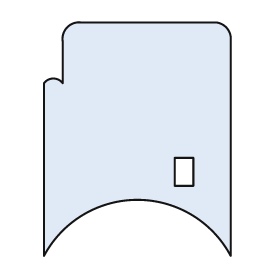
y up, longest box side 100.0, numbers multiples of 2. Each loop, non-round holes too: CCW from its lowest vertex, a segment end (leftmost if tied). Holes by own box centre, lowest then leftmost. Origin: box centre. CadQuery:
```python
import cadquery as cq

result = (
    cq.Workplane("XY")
    .moveTo(-40.0, -50.0)
    .threePointArc((0.0, -26.0), (40.0, -50.0))
    .lineTo(40.0, 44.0)
    .threePointArc((38.0, 48.0), (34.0, 50.0))
    .lineTo(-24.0, 50.0)
    .threePointArc((-30.0, 48.0), (-32.0, 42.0))
    .lineTo(-32.0, 24.0)
    .threePointArc((-36.0, 26.0), (-40.0, 24.0))
    .close()
    .moveTo(16.0, -20.0)
    .lineTo(24.0, -20.0)
    .lineTo(24.0, -8.0)
    .lineTo(16.0, -8.0)
    .close()
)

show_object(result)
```